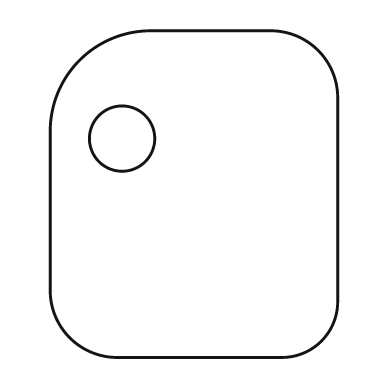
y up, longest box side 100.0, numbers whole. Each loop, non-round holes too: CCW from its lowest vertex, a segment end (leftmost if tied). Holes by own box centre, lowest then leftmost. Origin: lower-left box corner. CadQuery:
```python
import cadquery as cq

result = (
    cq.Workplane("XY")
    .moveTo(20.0, 0.0)
    .lineTo(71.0, 0.0)
    .threePointArc((83.0, 5.0), (88.0, 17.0))
    .lineTo(88.0, 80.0)
    .threePointArc((82.0, 94.0), (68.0, 100.0))
    .lineTo(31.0, 100.0)
    .threePointArc((9.0, 91.0), (0.0, 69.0))
    .lineTo(0.0, 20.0)
    .threePointArc((6.0, 6.0), (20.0, 0.0))
    .close()
    .moveTo(22.0, 67.0)
    .circle(10.0)
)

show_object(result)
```